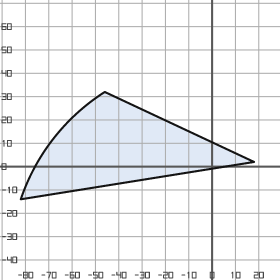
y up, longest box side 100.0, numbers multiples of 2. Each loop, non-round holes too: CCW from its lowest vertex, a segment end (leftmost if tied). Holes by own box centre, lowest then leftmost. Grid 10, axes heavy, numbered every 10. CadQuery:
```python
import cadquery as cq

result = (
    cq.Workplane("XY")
    .moveTo(-82.0, -14.0)
    .lineTo(18.0, 2.0)
    .lineTo(-46.0, 32.0)
    .threePointArc((-68.0, 12.0), (-82.0, -14.0))
    .close()
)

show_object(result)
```